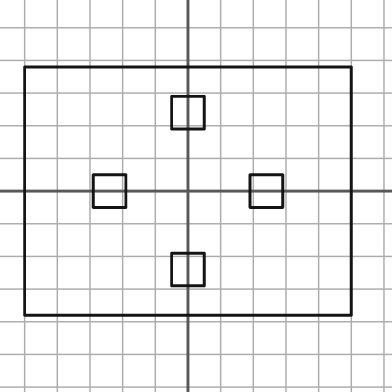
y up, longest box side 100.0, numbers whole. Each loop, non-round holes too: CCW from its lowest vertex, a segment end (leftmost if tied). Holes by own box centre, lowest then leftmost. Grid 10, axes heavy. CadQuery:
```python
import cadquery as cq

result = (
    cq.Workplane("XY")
    .moveTo(-50.0, -38.0)
    .lineTo(50.0, -38.0)
    .lineTo(50.0, 38.0)
    .lineTo(-50.0, 38.0)
    .close()
    .moveTo(-5.0, -29.0)
    .lineTo(5.0, -29.0)
    .lineTo(5.0, -19.0)
    .lineTo(-5.0, -19.0)
    .close()
    .moveTo(-29.0, -5.0)
    .lineTo(-19.0, -5.0)
    .lineTo(-19.0, 5.0)
    .lineTo(-29.0, 5.0)
    .close()
    .moveTo(19.0, -5.0)
    .lineTo(29.0, -5.0)
    .lineTo(29.0, 5.0)
    .lineTo(19.0, 5.0)
    .close()
    .moveTo(-5.0, 19.0)
    .lineTo(5.0, 19.0)
    .lineTo(5.0, 29.0)
    .lineTo(-5.0, 29.0)
    .close()
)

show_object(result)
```